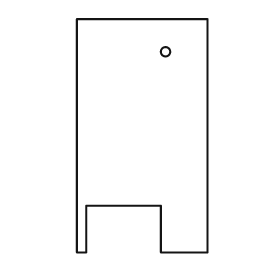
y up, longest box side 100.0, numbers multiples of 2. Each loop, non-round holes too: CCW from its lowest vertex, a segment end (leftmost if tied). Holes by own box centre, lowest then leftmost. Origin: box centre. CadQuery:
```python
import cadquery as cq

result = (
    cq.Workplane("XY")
    .moveTo(-28.0, -50.0)
    .lineTo(-24.0, -50.0)
    .lineTo(-24.0, -30.0)
    .lineTo(8.0, -30.0)
    .lineTo(8.0, -50.0)
    .lineTo(28.0, -50.0)
    .lineTo(28.0, 50.0)
    .lineTo(-28.0, 50.0)
    .close()
    .moveTo(10.0, 36.0)
    .circle(2.0)
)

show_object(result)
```